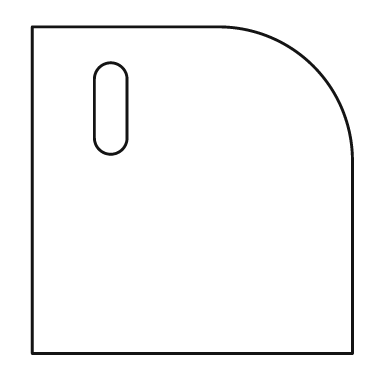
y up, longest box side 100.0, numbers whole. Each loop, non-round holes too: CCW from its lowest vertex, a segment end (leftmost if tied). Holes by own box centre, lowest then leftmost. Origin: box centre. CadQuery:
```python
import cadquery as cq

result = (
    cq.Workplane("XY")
    .moveTo(-49.0, -50.0)
    .lineTo(49.0, -50.0)
    .lineTo(49.0, 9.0)
    .threePointArc((37.0, 38.0), (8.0, 50.0))
    .lineTo(-49.0, 50.0)
    .close()
    .moveTo(-30.0, 16.0)
    .threePointArc((-25.0, 11.0), (-20.0, 16.0))
    .lineTo(-20.0, 34.0)
    .threePointArc((-25.0, 39.0), (-30.0, 34.0))
    .close()
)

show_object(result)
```